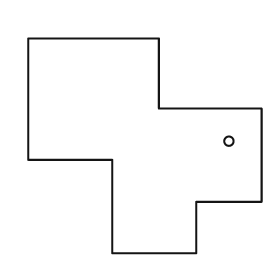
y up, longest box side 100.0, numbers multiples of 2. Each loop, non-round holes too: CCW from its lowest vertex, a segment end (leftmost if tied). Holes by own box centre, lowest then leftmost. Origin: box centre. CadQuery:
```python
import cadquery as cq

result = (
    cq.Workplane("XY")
    .moveTo(-14.0, -46.0)
    .lineTo(22.0, -46.0)
    .lineTo(22.0, -24.0)
    .lineTo(50.0, -24.0)
    .lineTo(50.0, 16.0)
    .lineTo(6.0, 16.0)
    .lineTo(6.0, 46.0)
    .lineTo(-50.0, 46.0)
    .lineTo(-50.0, -6.0)
    .lineTo(-14.0, -6.0)
    .close()
    .moveTo(36.0, 2.0)
    .circle(2.0)
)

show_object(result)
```